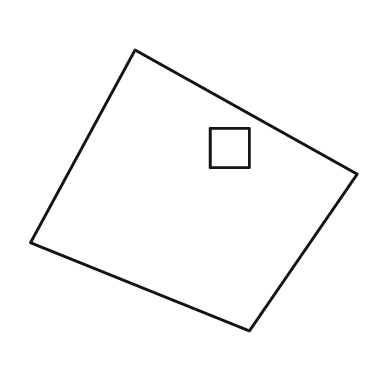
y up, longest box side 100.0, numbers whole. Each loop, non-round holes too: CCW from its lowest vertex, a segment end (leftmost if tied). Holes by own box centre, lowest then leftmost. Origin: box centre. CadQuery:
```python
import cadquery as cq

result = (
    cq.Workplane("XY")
    .moveTo(17.0, -43.0)
    .lineTo(50.0, 5.0)
    .lineTo(-18.0, 43.0)
    .lineTo(-50.0, -16.0)
    .close()
    .moveTo(5.0, 7.0)
    .lineTo(17.0, 7.0)
    .lineTo(17.0, 19.0)
    .lineTo(5.0, 19.0)
    .close()
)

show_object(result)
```